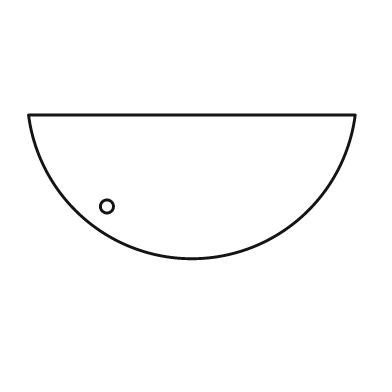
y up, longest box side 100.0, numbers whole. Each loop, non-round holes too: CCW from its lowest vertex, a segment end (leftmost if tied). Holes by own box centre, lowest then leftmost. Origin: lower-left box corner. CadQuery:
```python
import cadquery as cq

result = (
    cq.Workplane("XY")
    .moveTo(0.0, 44.0)
    .threePointArc((50.0, 0.0), (100.0, 44.0))
    .close()
    .moveTo(24.0, 16.0)
    .circle(2.0)
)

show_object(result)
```